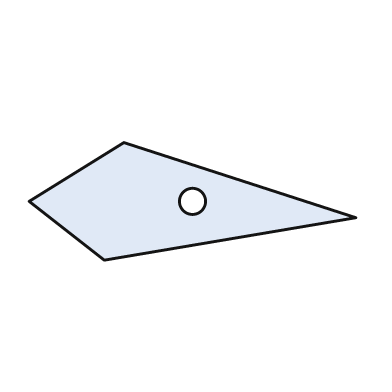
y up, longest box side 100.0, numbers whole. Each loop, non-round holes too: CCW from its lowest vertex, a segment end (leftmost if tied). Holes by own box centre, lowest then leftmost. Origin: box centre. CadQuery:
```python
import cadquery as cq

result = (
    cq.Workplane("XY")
    .moveTo(-27.0, -18.0)
    .lineTo(50.0, -5.0)
    .lineTo(-21.0, 18.0)
    .lineTo(-50.0, 0.0)
    .close()
    .moveTo(0.0, 0.0)
    .circle(4.0)
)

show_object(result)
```